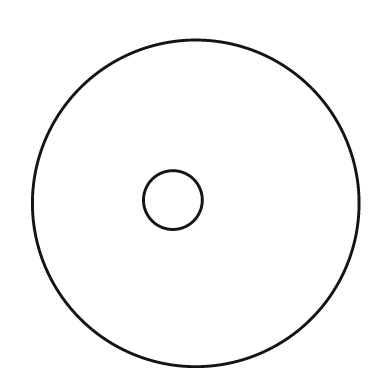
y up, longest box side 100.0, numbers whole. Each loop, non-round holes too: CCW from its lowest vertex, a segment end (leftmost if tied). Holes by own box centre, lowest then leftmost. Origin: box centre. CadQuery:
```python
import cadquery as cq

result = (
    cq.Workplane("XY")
    .moveTo(0.0, 0.0)
    .circle(50.0)
    .moveTo(-7.0, 1.0)
    .circle(9.0)
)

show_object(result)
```